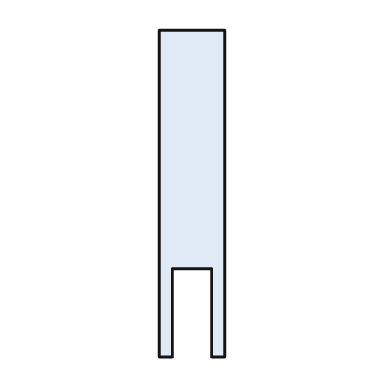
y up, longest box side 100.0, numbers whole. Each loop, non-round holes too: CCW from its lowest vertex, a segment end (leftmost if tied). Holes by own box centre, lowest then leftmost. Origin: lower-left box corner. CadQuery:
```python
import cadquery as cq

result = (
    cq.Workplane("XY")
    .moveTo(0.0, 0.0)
    .lineTo(4.0, 0.0)
    .lineTo(4.0, 27.0)
    .lineTo(16.0, 27.0)
    .lineTo(16.0, 0.0)
    .lineTo(20.0, 0.0)
    .lineTo(20.0, 100.0)
    .lineTo(0.0, 100.0)
    .close()
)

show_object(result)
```